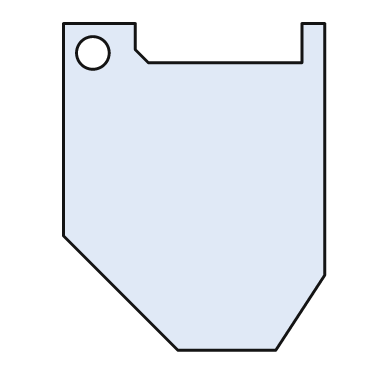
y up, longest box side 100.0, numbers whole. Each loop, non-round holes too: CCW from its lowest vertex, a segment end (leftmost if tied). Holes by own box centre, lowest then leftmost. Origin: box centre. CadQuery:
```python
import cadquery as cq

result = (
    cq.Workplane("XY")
    .moveTo(-5.0, -50.0)
    .lineTo(25.0, -50.0)
    .lineTo(40.0, -27.0)
    .lineTo(40.0, 50.0)
    .lineTo(33.0, 50.0)
    .lineTo(33.0, 38.0)
    .lineTo(-14.0, 38.0)
    .lineTo(-18.0, 42.0)
    .lineTo(-18.0, 50.0)
    .lineTo(-40.0, 50.0)
    .lineTo(-40.0, -15.0)
    .close()
    .moveTo(-31.0, 41.0)
    .circle(5.0)
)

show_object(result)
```